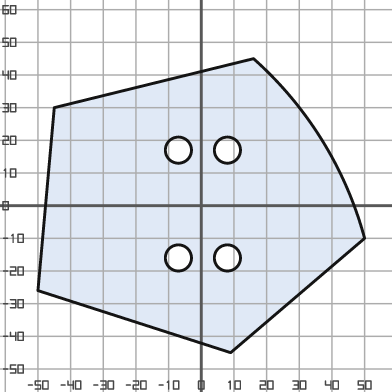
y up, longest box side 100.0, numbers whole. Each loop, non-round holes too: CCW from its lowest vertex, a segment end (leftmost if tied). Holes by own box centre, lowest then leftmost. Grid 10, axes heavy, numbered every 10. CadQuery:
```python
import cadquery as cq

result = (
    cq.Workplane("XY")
    .moveTo(9.0, -45.0)
    .lineTo(50.0, -10.0)
    .threePointArc((37.0, 20.0), (16.0, 45.0))
    .lineTo(-45.0, 30.0)
    .lineTo(-50.0, -26.0)
    .close()
    .moveTo(-7.0, -16.0)
    .circle(4.0)
    .moveTo(8.0, -16.0)
    .circle(4.0)
    .moveTo(-7.0, 17.0)
    .circle(4.0)
    .moveTo(8.0, 17.0)
    .circle(4.0)
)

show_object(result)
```